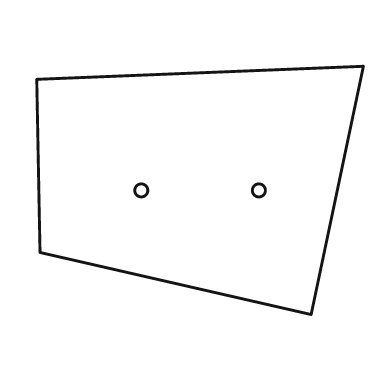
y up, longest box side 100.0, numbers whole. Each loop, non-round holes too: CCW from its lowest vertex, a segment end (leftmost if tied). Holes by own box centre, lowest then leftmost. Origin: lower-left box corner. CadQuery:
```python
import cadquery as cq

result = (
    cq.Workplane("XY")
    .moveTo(84.0, 0.0)
    .lineTo(100.0, 76.0)
    .lineTo(0.0, 72.0)
    .lineTo(1.0, 19.0)
    .close()
    .moveTo(32.0, 38.0)
    .circle(2.0)
    .moveTo(68.0, 38.0)
    .circle(2.0)
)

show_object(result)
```